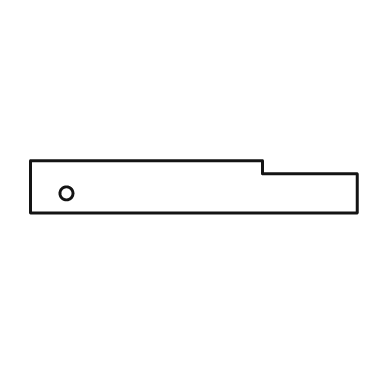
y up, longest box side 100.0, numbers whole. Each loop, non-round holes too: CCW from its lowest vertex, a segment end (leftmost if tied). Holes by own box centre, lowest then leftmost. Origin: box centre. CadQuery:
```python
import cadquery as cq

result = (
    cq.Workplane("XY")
    .moveTo(-50.0, -8.0)
    .lineTo(50.0, -8.0)
    .lineTo(50.0, 4.0)
    .lineTo(21.0, 4.0)
    .lineTo(21.0, 8.0)
    .lineTo(-50.0, 8.0)
    .close()
    .moveTo(-39.0, -2.0)
    .circle(2.0)
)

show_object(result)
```